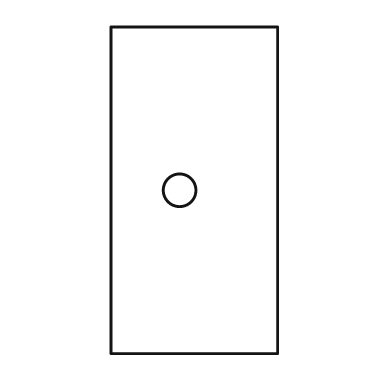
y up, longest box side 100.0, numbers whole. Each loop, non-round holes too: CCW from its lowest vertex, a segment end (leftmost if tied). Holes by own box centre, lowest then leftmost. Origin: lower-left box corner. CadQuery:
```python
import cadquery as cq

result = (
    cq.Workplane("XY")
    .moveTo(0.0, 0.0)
    .lineTo(51.0, 0.0)
    .lineTo(51.0, 100.0)
    .lineTo(0.0, 100.0)
    .close()
    .moveTo(21.0, 50.0)
    .circle(5.0)
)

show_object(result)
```